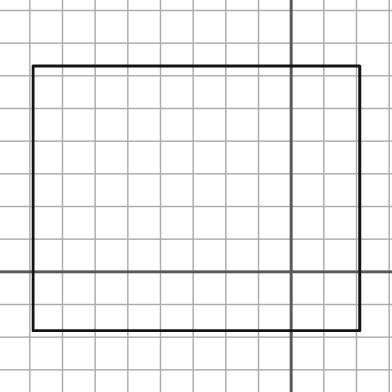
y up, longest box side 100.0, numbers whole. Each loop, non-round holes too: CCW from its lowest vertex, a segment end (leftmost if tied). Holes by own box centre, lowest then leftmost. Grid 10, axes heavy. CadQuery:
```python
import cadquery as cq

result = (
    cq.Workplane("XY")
    .moveTo(-79.0, -18.0)
    .lineTo(21.0, -18.0)
    .lineTo(21.0, 63.0)
    .lineTo(-79.0, 63.0)
    .close()
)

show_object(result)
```